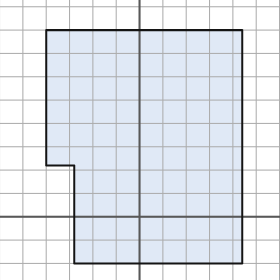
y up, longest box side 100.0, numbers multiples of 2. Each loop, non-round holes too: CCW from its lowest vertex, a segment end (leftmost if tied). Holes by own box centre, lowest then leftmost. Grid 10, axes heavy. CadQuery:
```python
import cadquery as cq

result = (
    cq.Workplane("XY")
    .moveTo(-28.0, -20.0)
    .lineTo(44.0, -20.0)
    .lineTo(44.0, 80.0)
    .lineTo(-40.0, 80.0)
    .lineTo(-40.0, 22.0)
    .lineTo(-28.0, 22.0)
    .close()
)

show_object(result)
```